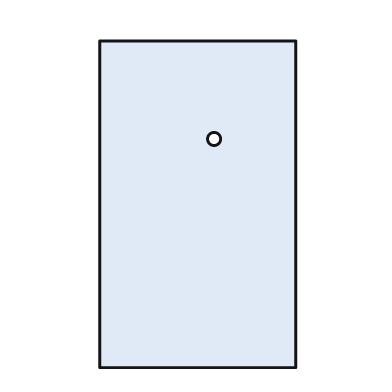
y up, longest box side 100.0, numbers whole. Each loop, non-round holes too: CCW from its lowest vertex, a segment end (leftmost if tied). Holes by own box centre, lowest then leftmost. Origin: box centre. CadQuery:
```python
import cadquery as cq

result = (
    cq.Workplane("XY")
    .moveTo(-30.0, -50.0)
    .lineTo(30.0, -50.0)
    .lineTo(30.0, 50.0)
    .lineTo(-30.0, 50.0)
    .close()
    .moveTo(5.0, 20.0)
    .circle(2.0)
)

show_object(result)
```